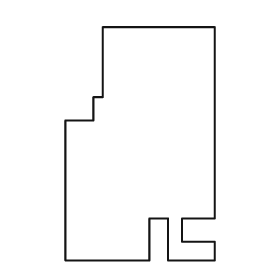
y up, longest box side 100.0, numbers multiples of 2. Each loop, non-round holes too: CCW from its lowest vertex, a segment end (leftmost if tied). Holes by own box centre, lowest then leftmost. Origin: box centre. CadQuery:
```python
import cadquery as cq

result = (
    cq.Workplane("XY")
    .moveTo(-32.0, -50.0)
    .lineTo(4.0, -50.0)
    .lineTo(4.0, -32.0)
    .lineTo(12.0, -32.0)
    .lineTo(12.0, -50.0)
    .lineTo(32.0, -50.0)
    .lineTo(32.0, -42.0)
    .lineTo(18.0, -42.0)
    .lineTo(18.0, -32.0)
    .lineTo(32.0, -32.0)
    .lineTo(32.0, 50.0)
    .lineTo(-16.0, 50.0)
    .lineTo(-16.0, 20.0)
    .lineTo(-20.0, 20.0)
    .lineTo(-20.0, 10.0)
    .lineTo(-32.0, 10.0)
    .close()
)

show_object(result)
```